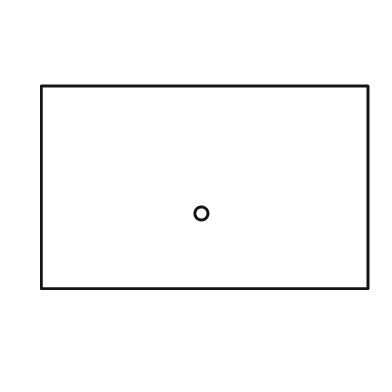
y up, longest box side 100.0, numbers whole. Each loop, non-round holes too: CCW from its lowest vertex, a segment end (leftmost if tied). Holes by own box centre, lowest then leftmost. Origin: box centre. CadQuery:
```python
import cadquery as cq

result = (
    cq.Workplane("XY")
    .moveTo(-50.0, -31.0)
    .lineTo(50.0, -31.0)
    .lineTo(50.0, 31.0)
    .lineTo(-50.0, 31.0)
    .close()
    .moveTo(-1.0, -8.0)
    .circle(2.0)
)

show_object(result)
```